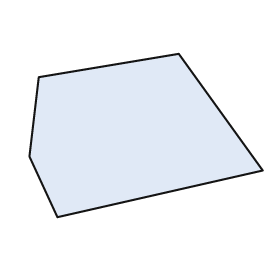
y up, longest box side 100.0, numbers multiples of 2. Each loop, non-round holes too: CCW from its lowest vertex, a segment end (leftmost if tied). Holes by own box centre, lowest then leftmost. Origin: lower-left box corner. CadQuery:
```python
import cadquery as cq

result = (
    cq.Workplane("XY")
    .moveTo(12.0, 0.0)
    .lineTo(100.0, 20.0)
    .lineTo(64.0, 70.0)
    .lineTo(4.0, 60.0)
    .lineTo(0.0, 26.0)
    .close()
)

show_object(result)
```